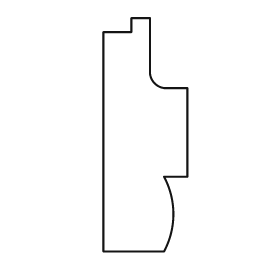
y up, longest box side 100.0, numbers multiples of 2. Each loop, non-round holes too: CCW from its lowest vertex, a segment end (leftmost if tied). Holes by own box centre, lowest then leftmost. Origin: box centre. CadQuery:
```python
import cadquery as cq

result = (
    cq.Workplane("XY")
    .moveTo(-18.0, -50.0)
    .lineTo(8.0, -50.0)
    .threePointArc((12.0, -34.0), (8.0, -18.0))
    .lineTo(18.0, -18.0)
    .lineTo(18.0, 20.0)
    .lineTo(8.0, 20.0)
    .threePointArc((4.0, 22.0), (2.0, 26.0))
    .lineTo(2.0, 50.0)
    .lineTo(-6.0, 50.0)
    .lineTo(-6.0, 44.0)
    .lineTo(-18.0, 44.0)
    .close()
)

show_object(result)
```